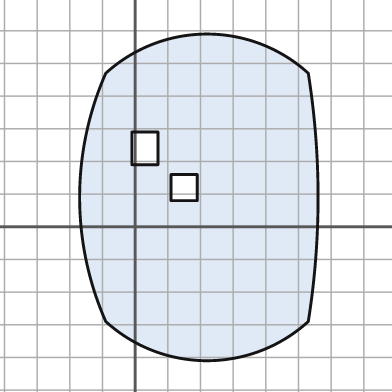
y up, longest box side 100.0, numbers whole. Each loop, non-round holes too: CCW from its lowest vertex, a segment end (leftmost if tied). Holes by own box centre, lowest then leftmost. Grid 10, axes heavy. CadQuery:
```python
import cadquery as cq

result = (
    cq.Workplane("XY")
    .moveTo(-9.0, -29.0)
    .threePointArc((22.0, -41.0), (53.0, -29.0))
    .threePointArc((56.0, 9.0), (53.0, 47.0))
    .threePointArc((22.0, 59.0), (-9.0, 47.0))
    .threePointArc((-17.0, 9.0), (-9.0, -29.0))
    .close()
    .moveTo(11.0, 8.0)
    .lineTo(19.0, 8.0)
    .lineTo(19.0, 16.0)
    .lineTo(11.0, 16.0)
    .close()
    .moveTo(-1.0, 19.0)
    .lineTo(7.0, 19.0)
    .lineTo(7.0, 29.0)
    .lineTo(-1.0, 29.0)
    .close()
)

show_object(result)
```